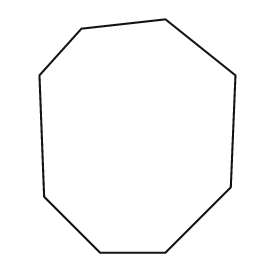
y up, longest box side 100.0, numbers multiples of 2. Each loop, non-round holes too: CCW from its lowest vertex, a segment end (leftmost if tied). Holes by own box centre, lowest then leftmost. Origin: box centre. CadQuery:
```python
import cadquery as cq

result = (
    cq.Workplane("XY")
    .moveTo(-16.0, -50.0)
    .lineTo(12.0, -50.0)
    .lineTo(40.0, -22.0)
    .lineTo(42.0, 26.0)
    .lineTo(12.0, 50.0)
    .lineTo(-24.0, 46.0)
    .lineTo(-42.0, 26.0)
    .lineTo(-40.0, -26.0)
    .close()
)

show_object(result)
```